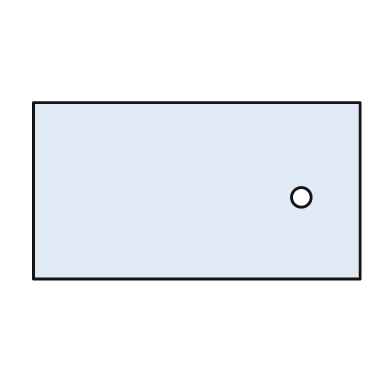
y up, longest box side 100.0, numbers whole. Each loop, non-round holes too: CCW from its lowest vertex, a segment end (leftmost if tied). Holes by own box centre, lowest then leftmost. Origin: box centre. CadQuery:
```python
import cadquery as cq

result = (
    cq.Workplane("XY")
    .moveTo(-50.0, -27.0)
    .lineTo(50.0, -27.0)
    .lineTo(50.0, 27.0)
    .lineTo(-50.0, 27.0)
    .close()
    .moveTo(32.0, -2.0)
    .circle(3.0)
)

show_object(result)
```